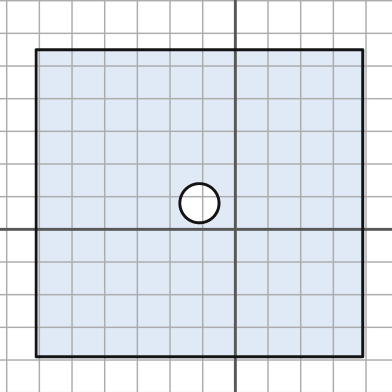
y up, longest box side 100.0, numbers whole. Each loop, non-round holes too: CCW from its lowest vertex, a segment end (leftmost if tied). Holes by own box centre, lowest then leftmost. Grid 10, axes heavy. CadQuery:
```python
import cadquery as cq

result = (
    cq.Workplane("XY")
    .moveTo(-61.0, -39.0)
    .lineTo(39.0, -39.0)
    .lineTo(39.0, 55.0)
    .lineTo(-61.0, 55.0)
    .close()
    .moveTo(-11.0, 8.0)
    .circle(6.0)
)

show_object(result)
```